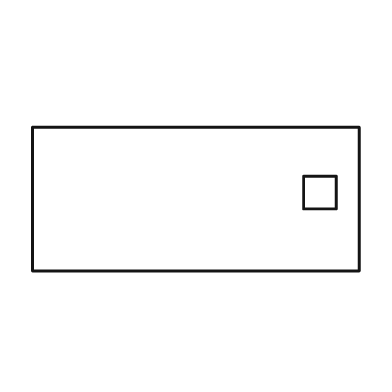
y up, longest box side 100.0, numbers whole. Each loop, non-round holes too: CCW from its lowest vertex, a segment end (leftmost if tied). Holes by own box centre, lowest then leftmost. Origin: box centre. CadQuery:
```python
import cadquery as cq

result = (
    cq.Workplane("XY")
    .moveTo(-50.0, -22.0)
    .lineTo(50.0, -22.0)
    .lineTo(50.0, 22.0)
    .lineTo(-50.0, 22.0)
    .close()
    .moveTo(33.0, -3.0)
    .lineTo(43.0, -3.0)
    .lineTo(43.0, 7.0)
    .lineTo(33.0, 7.0)
    .close()
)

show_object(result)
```